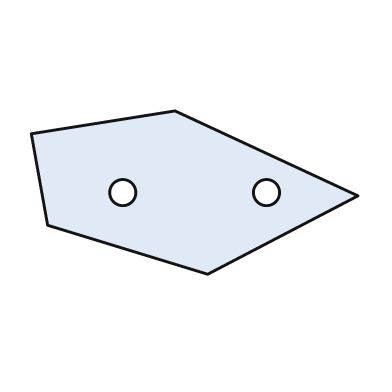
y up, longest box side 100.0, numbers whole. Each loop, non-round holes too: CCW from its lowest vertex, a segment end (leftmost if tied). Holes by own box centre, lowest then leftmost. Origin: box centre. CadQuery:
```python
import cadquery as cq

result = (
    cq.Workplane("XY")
    .moveTo(4.0, -25.0)
    .lineTo(50.0, -1.0)
    .lineTo(-6.0, 25.0)
    .lineTo(-50.0, 18.0)
    .lineTo(-45.0, -10.0)
    .close()
    .moveTo(-22.0, 0.0)
    .circle(4.0)
    .moveTo(22.0, 0.0)
    .circle(4.0)
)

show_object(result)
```